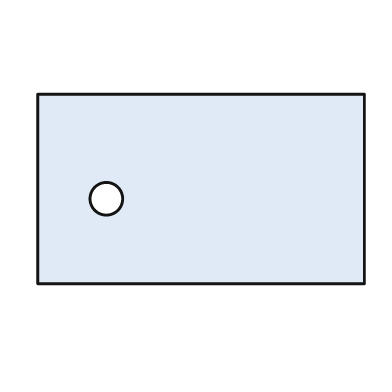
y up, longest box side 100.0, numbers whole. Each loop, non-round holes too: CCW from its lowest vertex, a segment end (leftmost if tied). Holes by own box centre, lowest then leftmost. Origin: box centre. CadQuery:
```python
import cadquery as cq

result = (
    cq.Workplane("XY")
    .moveTo(-50.0, -29.0)
    .lineTo(50.0, -29.0)
    .lineTo(50.0, 29.0)
    .lineTo(-50.0, 29.0)
    .close()
    .moveTo(-29.0, -3.0)
    .circle(5.0)
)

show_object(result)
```